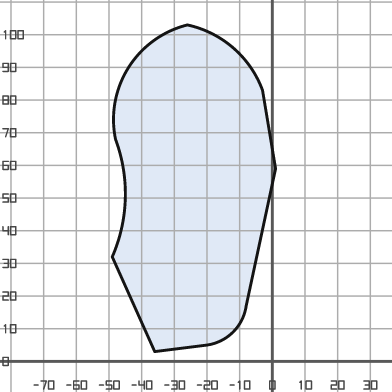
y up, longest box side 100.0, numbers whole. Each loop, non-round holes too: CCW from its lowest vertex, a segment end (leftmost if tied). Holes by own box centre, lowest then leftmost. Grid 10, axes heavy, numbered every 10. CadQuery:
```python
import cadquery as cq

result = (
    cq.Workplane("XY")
    .moveTo(-36.0, 3.0)
    .lineTo(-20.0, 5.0)
    .threePointArc((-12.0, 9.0), (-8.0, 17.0))
    .lineTo(1.0, 59.0)
    .lineTo(-3.0, 83.0)
    .threePointArc((-12.0, 96.0), (-26.0, 103.0))
    .threePointArc((-44.0, 90.0), (-48.0, 68.0))
    .threePointArc((-45.0, 50.0), (-49.0, 32.0))
    .close()
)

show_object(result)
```